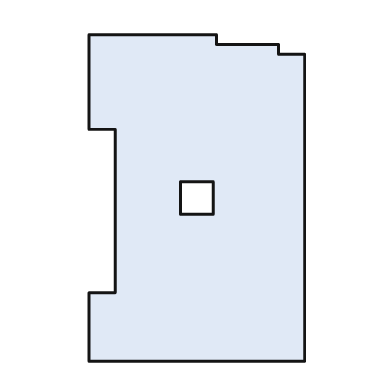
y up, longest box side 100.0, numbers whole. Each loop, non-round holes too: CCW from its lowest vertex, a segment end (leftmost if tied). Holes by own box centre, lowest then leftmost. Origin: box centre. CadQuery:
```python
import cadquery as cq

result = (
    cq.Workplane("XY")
    .moveTo(-33.0, -50.0)
    .lineTo(33.0, -50.0)
    .lineTo(33.0, 44.0)
    .lineTo(25.0, 44.0)
    .lineTo(25.0, 47.0)
    .lineTo(6.0, 47.0)
    .lineTo(6.0, 50.0)
    .lineTo(-33.0, 50.0)
    .lineTo(-33.0, 21.0)
    .lineTo(-25.0, 21.0)
    .lineTo(-25.0, -29.0)
    .lineTo(-33.0, -29.0)
    .close()
    .moveTo(-5.0, -5.0)
    .lineTo(5.0, -5.0)
    .lineTo(5.0, 5.0)
    .lineTo(-5.0, 5.0)
    .close()
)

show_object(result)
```